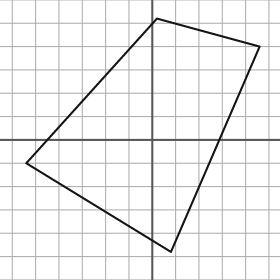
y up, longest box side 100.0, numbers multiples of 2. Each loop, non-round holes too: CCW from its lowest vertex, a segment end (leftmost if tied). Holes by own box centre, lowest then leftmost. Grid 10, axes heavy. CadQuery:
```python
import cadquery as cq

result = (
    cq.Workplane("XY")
    .moveTo(8.0, -48.0)
    .lineTo(46.0, 40.0)
    .lineTo(2.0, 52.0)
    .lineTo(-54.0, -10.0)
    .close()
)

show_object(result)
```